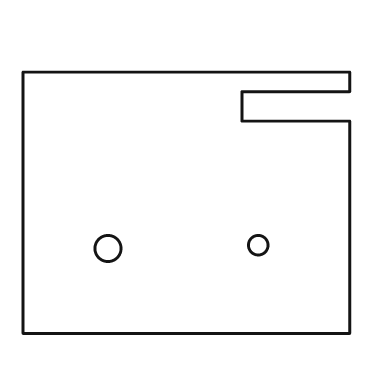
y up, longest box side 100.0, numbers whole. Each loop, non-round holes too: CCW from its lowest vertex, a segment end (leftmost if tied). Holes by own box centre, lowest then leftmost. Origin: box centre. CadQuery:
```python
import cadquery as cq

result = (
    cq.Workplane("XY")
    .moveTo(-50.0, -40.0)
    .lineTo(50.0, -40.0)
    .lineTo(50.0, 25.0)
    .lineTo(17.0, 25.0)
    .lineTo(17.0, 34.0)
    .lineTo(50.0, 34.0)
    .lineTo(50.0, 40.0)
    .lineTo(-50.0, 40.0)
    .close()
    .moveTo(-24.0, -14.0)
    .circle(4.0)
    .moveTo(22.0, -13.0)
    .circle(3.0)
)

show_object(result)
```